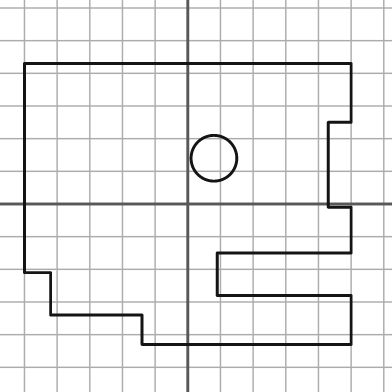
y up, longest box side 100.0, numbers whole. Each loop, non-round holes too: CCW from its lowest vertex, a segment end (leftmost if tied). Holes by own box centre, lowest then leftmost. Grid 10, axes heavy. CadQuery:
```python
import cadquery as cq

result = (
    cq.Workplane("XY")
    .moveTo(-14.0, -43.0)
    .lineTo(50.0, -43.0)
    .lineTo(50.0, -28.0)
    .lineTo(9.0, -28.0)
    .lineTo(9.0, -15.0)
    .lineTo(50.0, -15.0)
    .lineTo(50.0, -1.0)
    .lineTo(43.0, -1.0)
    .lineTo(43.0, 25.0)
    .lineTo(50.0, 25.0)
    .lineTo(50.0, 43.0)
    .lineTo(-50.0, 43.0)
    .lineTo(-50.0, -21.0)
    .lineTo(-42.0, -21.0)
    .lineTo(-42.0, -34.0)
    .lineTo(-14.0, -34.0)
    .close()
    .moveTo(8.0, 14.0)
    .circle(7.0)
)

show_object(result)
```